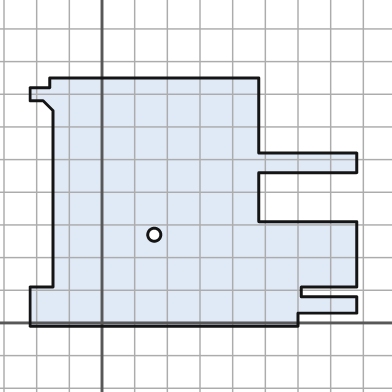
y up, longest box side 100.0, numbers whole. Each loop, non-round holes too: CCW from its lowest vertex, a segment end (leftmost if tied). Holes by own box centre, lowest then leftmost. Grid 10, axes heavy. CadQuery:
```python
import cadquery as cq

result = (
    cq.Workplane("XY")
    .moveTo(-22.0, -1.0)
    .lineTo(60.0, -1.0)
    .lineTo(60.0, 3.0)
    .lineTo(78.0, 3.0)
    .lineTo(78.0, 8.0)
    .lineTo(61.0, 8.0)
    .lineTo(61.0, 11.0)
    .lineTo(78.0, 11.0)
    .lineTo(78.0, 31.0)
    .lineTo(48.0, 31.0)
    .lineTo(48.0, 46.0)
    .lineTo(78.0, 46.0)
    .lineTo(78.0, 52.0)
    .lineTo(48.0, 52.0)
    .lineTo(48.0, 75.0)
    .lineTo(-16.0, 75.0)
    .lineTo(-16.0, 72.0)
    .lineTo(-22.0, 72.0)
    .lineTo(-22.0, 68.0)
    .lineTo(-18.0, 68.0)
    .lineTo(-15.0, 65.0)
    .lineTo(-15.0, 11.0)
    .lineTo(-22.0, 11.0)
    .close()
    .moveTo(16.0, 27.0)
    .circle(2.0)
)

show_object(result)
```